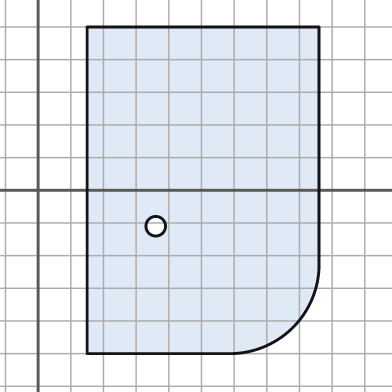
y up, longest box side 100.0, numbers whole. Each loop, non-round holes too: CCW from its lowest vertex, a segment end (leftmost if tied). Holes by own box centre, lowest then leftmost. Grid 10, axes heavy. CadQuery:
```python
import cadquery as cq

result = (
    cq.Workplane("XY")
    .moveTo(15.0, -50.0)
    .lineTo(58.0, -50.0)
    .threePointArc((78.0, -42.0), (86.0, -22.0))
    .lineTo(86.0, 50.0)
    .lineTo(15.0, 50.0)
    .close()
    .moveTo(36.0, -11.0)
    .circle(3.0)
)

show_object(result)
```